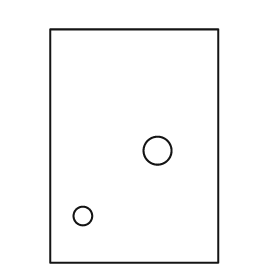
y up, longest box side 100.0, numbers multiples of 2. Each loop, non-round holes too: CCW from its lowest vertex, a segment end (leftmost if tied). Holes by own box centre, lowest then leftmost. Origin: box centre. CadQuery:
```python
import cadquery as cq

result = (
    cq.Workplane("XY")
    .moveTo(-36.0, -50.0)
    .lineTo(36.0, -50.0)
    .lineTo(36.0, 50.0)
    .lineTo(-36.0, 50.0)
    .close()
    .moveTo(-22.0, -30.0)
    .circle(4.0)
    .moveTo(10.0, -2.0)
    .circle(6.0)
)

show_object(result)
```